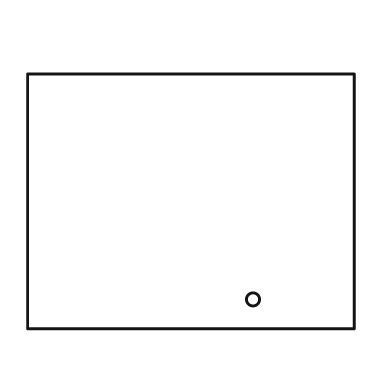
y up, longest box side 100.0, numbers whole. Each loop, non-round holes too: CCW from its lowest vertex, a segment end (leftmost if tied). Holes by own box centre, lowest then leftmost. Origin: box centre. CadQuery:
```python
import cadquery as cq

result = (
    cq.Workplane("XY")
    .moveTo(-50.0, -39.0)
    .lineTo(50.0, -39.0)
    .lineTo(50.0, 39.0)
    .lineTo(-50.0, 39.0)
    .close()
    .moveTo(19.0, -30.0)
    .circle(2.0)
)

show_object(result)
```